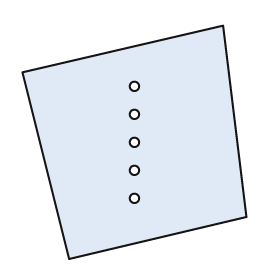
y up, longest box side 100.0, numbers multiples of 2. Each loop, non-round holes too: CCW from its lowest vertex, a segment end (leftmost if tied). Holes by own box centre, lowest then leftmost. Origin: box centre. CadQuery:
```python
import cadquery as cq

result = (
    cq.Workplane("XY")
    .moveTo(-28.0, -50.0)
    .lineTo(48.0, -32.0)
    .lineTo(38.0, 50.0)
    .lineTo(-48.0, 30.0)
    .close()
    .moveTo(0.0, -24.0)
    .circle(2.0)
    .moveTo(0.0, -12.0)
    .circle(2.0)
    .moveTo(0.0, 0.0)
    .circle(2.0)
    .moveTo(0.0, 12.0)
    .circle(2.0)
    .moveTo(0.0, 24.0)
    .circle(2.0)
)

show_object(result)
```